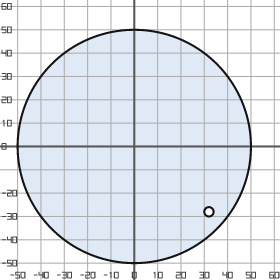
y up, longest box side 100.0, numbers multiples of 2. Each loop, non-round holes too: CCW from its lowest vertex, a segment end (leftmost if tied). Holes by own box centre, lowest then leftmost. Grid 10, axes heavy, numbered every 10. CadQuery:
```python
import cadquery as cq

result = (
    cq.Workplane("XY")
    .moveTo(0.0, 0.0)
    .circle(50.0)
    .moveTo(32.0, -28.0)
    .circle(2.0)
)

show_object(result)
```